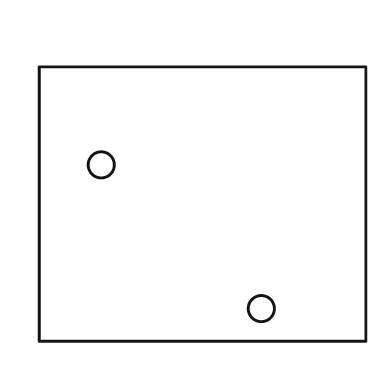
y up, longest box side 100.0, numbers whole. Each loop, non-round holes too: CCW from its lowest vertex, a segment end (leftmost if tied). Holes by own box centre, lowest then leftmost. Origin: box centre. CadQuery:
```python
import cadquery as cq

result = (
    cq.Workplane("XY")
    .moveTo(-50.0, -42.0)
    .lineTo(50.0, -42.0)
    .lineTo(50.0, 42.0)
    .lineTo(-50.0, 42.0)
    .close()
    .moveTo(18.0, -32.0)
    .circle(4.0)
    .moveTo(-31.0, 12.0)
    .circle(4.0)
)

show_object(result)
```